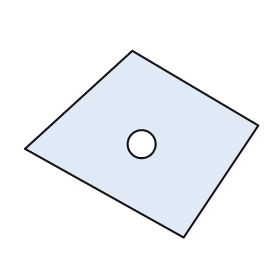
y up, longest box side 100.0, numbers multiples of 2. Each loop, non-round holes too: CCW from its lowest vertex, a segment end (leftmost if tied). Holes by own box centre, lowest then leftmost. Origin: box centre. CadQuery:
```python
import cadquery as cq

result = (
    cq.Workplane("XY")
    .moveTo(18.0, -40.0)
    .lineTo(50.0, 8.0)
    .lineTo(-4.0, 40.0)
    .lineTo(-50.0, -2.0)
    .close()
    .moveTo(0.0, 0.0)
    .circle(6.0)
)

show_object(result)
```